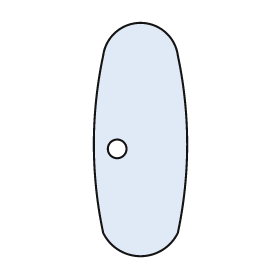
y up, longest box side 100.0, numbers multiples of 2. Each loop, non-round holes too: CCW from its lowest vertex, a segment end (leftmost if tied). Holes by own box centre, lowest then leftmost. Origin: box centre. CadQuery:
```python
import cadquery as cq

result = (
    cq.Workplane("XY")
    .moveTo(-16.0, -40.0)
    .threePointArc((0.0, -50.0), (16.0, -40.0))
    .threePointArc((20.0, -2.0), (16.0, 36.0))
    .threePointArc((0.0, 50.0), (-16.0, 36.0))
    .threePointArc((-20.0, -2.0), (-16.0, -40.0))
    .close()
    .moveTo(-10.0, -4.0)
    .circle(4.0)
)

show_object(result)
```